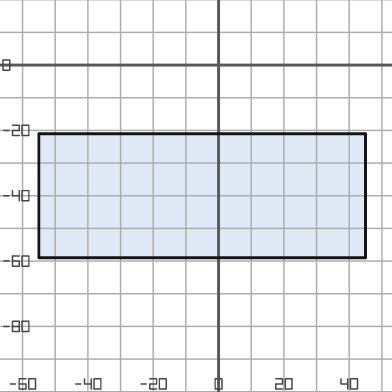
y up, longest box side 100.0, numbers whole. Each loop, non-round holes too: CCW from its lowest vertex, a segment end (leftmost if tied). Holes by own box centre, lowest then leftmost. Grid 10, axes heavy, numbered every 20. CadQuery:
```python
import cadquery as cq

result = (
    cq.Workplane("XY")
    .moveTo(-55.0, -59.0)
    .lineTo(45.0, -59.0)
    .lineTo(45.0, -21.0)
    .lineTo(-55.0, -21.0)
    .close()
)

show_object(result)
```